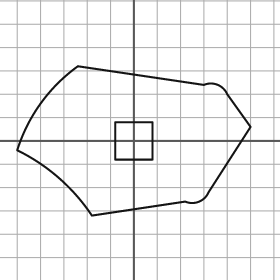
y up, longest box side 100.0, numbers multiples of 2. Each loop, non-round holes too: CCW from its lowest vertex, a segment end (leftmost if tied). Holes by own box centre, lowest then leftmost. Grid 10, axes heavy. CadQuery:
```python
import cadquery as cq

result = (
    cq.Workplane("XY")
    .moveTo(-18.0, -32.0)
    .lineTo(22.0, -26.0)
    .threePointArc((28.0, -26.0), (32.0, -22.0))
    .lineTo(50.0, 6.0)
    .lineTo(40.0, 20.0)
    .threePointArc((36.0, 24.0), (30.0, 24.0))
    .lineTo(-24.0, 32.0)
    .threePointArc((-40.0, 16.0), (-50.0, -4.0))
    .threePointArc((-32.0, -16.0), (-18.0, -32.0))
    .close()
    .moveTo(-8.0, -8.0)
    .lineTo(8.0, -8.0)
    .lineTo(8.0, 8.0)
    .lineTo(-8.0, 8.0)
    .close()
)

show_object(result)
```